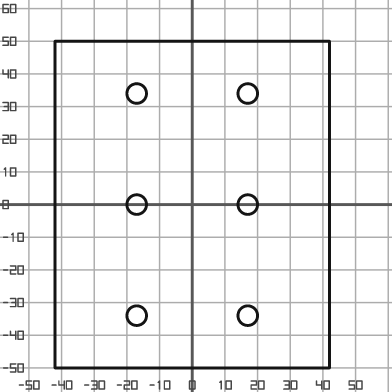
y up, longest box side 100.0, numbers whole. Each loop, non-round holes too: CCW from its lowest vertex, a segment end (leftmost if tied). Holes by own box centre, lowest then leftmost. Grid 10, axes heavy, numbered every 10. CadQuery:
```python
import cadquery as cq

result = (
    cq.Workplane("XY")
    .moveTo(-42.0, -50.0)
    .lineTo(42.0, -50.0)
    .lineTo(42.0, 50.0)
    .lineTo(-42.0, 50.0)
    .close()
    .moveTo(-17.0, -34.0)
    .circle(3.0)
    .moveTo(17.0, -34.0)
    .circle(3.0)
    .moveTo(-17.0, 0.0)
    .circle(3.0)
    .moveTo(17.0, 0.0)
    .circle(3.0)
    .moveTo(-17.0, 34.0)
    .circle(3.0)
    .moveTo(17.0, 34.0)
    .circle(3.0)
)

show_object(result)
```